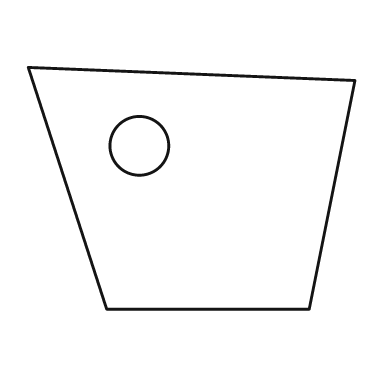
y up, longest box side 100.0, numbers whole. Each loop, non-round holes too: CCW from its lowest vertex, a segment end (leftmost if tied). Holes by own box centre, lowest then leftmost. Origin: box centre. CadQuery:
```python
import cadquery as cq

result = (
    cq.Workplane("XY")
    .moveTo(-26.0, -37.0)
    .lineTo(36.0, -37.0)
    .lineTo(50.0, 33.0)
    .lineTo(-50.0, 37.0)
    .close()
    .moveTo(-16.0, 13.0)
    .circle(9.0)
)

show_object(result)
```